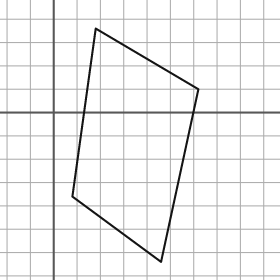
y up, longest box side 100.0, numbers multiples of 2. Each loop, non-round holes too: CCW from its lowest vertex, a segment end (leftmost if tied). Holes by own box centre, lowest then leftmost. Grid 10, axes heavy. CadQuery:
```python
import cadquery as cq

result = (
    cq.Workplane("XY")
    .moveTo(46.0, -64.0)
    .lineTo(62.0, 10.0)
    .lineTo(18.0, 36.0)
    .lineTo(8.0, -36.0)
    .close()
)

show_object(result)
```